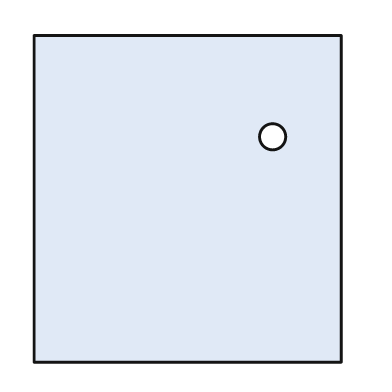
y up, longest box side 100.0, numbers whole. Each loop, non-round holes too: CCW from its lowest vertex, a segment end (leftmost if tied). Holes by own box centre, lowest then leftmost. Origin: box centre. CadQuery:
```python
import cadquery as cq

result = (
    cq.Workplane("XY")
    .moveTo(-47.0, -50.0)
    .lineTo(47.0, -50.0)
    .lineTo(47.0, 50.0)
    .lineTo(-47.0, 50.0)
    .close()
    .moveTo(26.0, 19.0)
    .circle(4.0)
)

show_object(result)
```